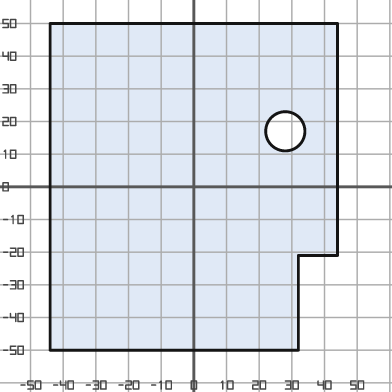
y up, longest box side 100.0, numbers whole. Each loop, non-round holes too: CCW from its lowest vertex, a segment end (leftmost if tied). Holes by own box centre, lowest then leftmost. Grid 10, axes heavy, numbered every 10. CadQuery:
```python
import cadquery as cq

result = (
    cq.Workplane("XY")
    .moveTo(-44.0, -50.0)
    .lineTo(32.0, -50.0)
    .lineTo(32.0, -21.0)
    .lineTo(44.0, -21.0)
    .lineTo(44.0, 50.0)
    .lineTo(-44.0, 50.0)
    .close()
    .moveTo(28.0, 17.0)
    .circle(6.0)
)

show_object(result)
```